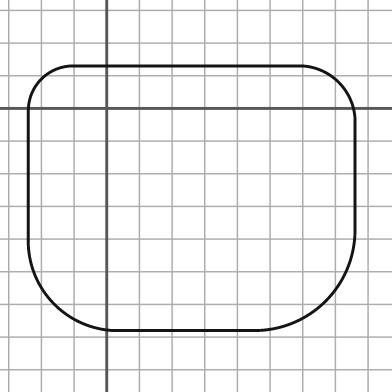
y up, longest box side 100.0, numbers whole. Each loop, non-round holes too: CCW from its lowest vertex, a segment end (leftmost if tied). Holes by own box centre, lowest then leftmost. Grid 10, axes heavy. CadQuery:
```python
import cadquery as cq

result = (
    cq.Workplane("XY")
    .moveTo(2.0, -68.0)
    .lineTo(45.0, -68.0)
    .threePointArc((67.0, -59.0), (76.0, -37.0))
    .lineTo(76.0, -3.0)
    .threePointArc((71.0, 8.0), (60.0, 13.0))
    .lineTo(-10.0, 13.0)
    .threePointArc((-20.0, 9.0), (-24.0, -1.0))
    .lineTo(-24.0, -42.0)
    .threePointArc((-16.0, -60.0), (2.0, -68.0))
    .close()
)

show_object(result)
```